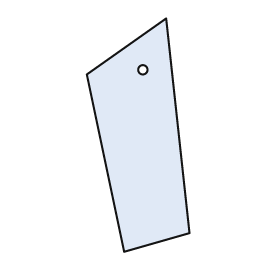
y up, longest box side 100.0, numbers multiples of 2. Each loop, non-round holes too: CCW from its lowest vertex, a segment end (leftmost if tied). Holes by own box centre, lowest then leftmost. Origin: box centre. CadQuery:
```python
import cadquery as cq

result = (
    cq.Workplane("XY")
    .moveTo(-6.0, -50.0)
    .lineTo(22.0, -42.0)
    .lineTo(12.0, 50.0)
    .lineTo(-22.0, 26.0)
    .close()
    .moveTo(2.0, 28.0)
    .circle(2.0)
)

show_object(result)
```